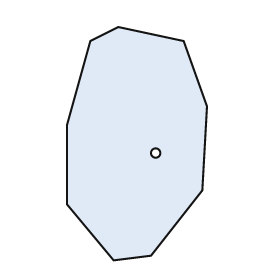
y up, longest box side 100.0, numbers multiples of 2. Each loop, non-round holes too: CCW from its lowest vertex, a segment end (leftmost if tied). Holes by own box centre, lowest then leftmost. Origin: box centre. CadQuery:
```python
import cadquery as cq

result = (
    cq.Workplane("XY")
    .moveTo(-10.0, -50.0)
    .lineTo(6.0, -48.0)
    .lineTo(28.0, -20.0)
    .lineTo(30.0, 16.0)
    .lineTo(20.0, 44.0)
    .lineTo(-8.0, 50.0)
    .lineTo(-20.0, 44.0)
    .lineTo(-30.0, 8.0)
    .lineTo(-30.0, -26.0)
    .close()
    .moveTo(8.0, -4.0)
    .circle(2.0)
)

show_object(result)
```